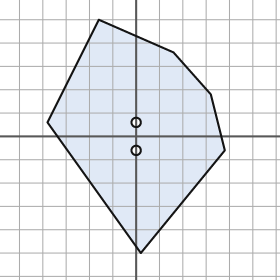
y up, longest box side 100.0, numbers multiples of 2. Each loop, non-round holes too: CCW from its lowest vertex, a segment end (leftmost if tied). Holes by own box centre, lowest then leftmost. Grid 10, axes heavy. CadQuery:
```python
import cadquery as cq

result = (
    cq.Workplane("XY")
    .moveTo(2.0, -50.0)
    .lineTo(38.0, -6.0)
    .lineTo(32.0, 18.0)
    .lineTo(16.0, 36.0)
    .lineTo(-16.0, 50.0)
    .lineTo(-38.0, 6.0)
    .close()
    .moveTo(0.0, -6.0)
    .circle(2.0)
    .moveTo(0.0, 6.0)
    .circle(2.0)
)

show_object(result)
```